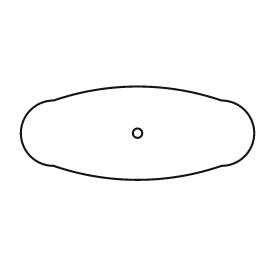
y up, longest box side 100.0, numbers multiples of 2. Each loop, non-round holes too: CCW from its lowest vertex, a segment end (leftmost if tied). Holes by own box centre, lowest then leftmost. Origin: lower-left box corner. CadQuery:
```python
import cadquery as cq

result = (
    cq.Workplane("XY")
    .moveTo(14.0, 6.0)
    .threePointArc((50.0, 0.0), (86.0, 6.0))
    .threePointArc((100.0, 20.0), (86.0, 34.0))
    .threePointArc((50.0, 40.0), (14.0, 34.0))
    .threePointArc((0.0, 20.0), (14.0, 6.0))
    .close()
    .moveTo(50.0, 20.0)
    .circle(2.0)
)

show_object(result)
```